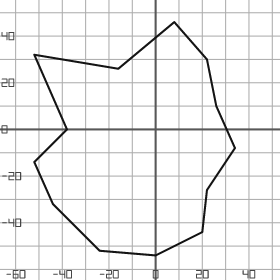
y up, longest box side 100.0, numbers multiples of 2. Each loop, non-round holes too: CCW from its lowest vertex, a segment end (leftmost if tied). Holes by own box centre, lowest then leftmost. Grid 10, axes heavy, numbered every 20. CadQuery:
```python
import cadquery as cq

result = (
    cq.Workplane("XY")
    .moveTo(0.0, -54.0)
    .lineTo(20.0, -44.0)
    .lineTo(22.0, -26.0)
    .lineTo(34.0, -8.0)
    .lineTo(26.0, 10.0)
    .lineTo(22.0, 30.0)
    .lineTo(8.0, 46.0)
    .lineTo(-16.0, 26.0)
    .lineTo(-52.0, 32.0)
    .lineTo(-38.0, 0.0)
    .lineTo(-52.0, -14.0)
    .lineTo(-44.0, -32.0)
    .lineTo(-24.0, -52.0)
    .close()
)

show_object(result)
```